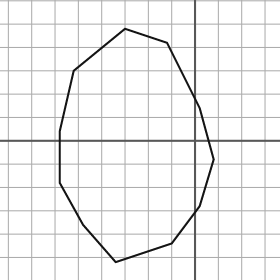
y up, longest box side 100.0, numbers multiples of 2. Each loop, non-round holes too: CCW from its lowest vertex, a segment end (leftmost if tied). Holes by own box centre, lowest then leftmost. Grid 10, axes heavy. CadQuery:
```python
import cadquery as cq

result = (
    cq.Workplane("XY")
    .moveTo(-34.0, -52.0)
    .lineTo(-10.0, -44.0)
    .lineTo(2.0, -28.0)
    .lineTo(8.0, -8.0)
    .lineTo(2.0, 14.0)
    .lineTo(-12.0, 42.0)
    .lineTo(-30.0, 48.0)
    .lineTo(-52.0, 30.0)
    .lineTo(-58.0, 4.0)
    .lineTo(-58.0, -18.0)
    .lineTo(-48.0, -36.0)
    .close()
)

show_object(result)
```